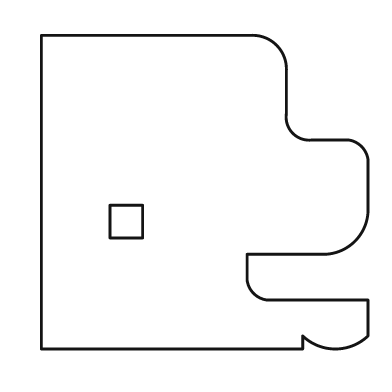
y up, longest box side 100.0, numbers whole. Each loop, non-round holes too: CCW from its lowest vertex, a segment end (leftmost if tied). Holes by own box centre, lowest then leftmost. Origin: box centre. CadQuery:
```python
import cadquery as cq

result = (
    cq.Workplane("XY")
    .moveTo(-50.0, -48.0)
    .lineTo(30.0, -48.0)
    .lineTo(30.0, -44.0)
    .threePointArc((40.0, -48.0), (50.0, -44.0))
    .lineTo(50.0, -33.0)
    .lineTo(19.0, -33.0)
    .threePointArc((15.0, -31.0), (13.0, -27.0))
    .lineTo(13.0, -19.0)
    .lineTo(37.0, -19.0)
    .threePointArc((46.0, -15.0), (50.0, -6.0))
    .lineTo(50.0, 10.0)
    .threePointArc((48.0, 14.0), (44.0, 16.0))
    .lineTo(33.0, 16.0)
    .threePointArc((27.0, 18.0), (25.0, 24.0))
    .lineTo(25.0, 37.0)
    .threePointArc((22.0, 45.0), (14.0, 48.0))
    .lineTo(-50.0, 48.0)
    .close()
    .moveTo(-29.0, -14.0)
    .lineTo(-19.0, -14.0)
    .lineTo(-19.0, -4.0)
    .lineTo(-29.0, -4.0)
    .close()
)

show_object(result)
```